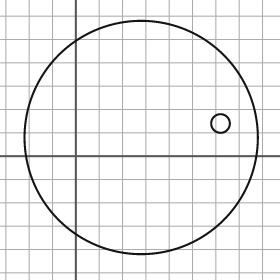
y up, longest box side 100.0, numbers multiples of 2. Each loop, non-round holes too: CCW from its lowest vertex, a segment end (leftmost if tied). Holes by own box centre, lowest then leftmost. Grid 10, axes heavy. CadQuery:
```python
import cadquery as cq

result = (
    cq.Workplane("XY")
    .moveTo(28.0, 8.0)
    .circle(50.0)
    .moveTo(62.0, 14.0)
    .circle(4.0)
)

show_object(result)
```